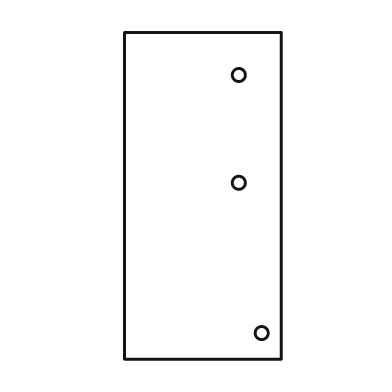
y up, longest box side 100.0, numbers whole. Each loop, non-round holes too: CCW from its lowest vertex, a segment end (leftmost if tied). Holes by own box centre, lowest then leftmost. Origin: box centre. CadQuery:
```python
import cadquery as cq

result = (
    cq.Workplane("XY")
    .moveTo(-24.0, -50.0)
    .lineTo(24.0, -50.0)
    .lineTo(24.0, 50.0)
    .lineTo(-24.0, 50.0)
    .close()
    .moveTo(18.0, -42.0)
    .circle(2.0)
    .moveTo(11.0, 4.0)
    .circle(2.0)
    .moveTo(11.0, 37.0)
    .circle(2.0)
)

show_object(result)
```